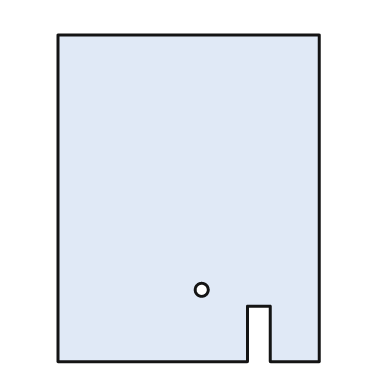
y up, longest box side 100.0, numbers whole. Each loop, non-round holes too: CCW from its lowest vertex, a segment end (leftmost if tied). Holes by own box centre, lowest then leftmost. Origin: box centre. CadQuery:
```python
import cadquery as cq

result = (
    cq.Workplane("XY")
    .moveTo(-40.0, -50.0)
    .lineTo(18.0, -50.0)
    .lineTo(18.0, -33.0)
    .lineTo(25.0, -33.0)
    .lineTo(25.0, -50.0)
    .lineTo(40.0, -50.0)
    .lineTo(40.0, 50.0)
    .lineTo(-40.0, 50.0)
    .close()
    .moveTo(4.0, -28.0)
    .circle(2.0)
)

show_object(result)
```